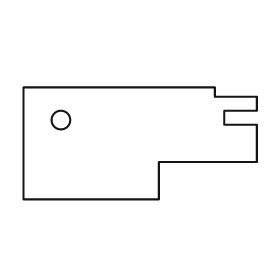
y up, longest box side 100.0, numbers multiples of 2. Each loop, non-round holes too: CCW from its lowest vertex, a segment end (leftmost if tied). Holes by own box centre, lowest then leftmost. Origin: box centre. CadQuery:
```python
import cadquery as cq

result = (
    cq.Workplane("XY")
    .moveTo(-50.0, -24.0)
    .lineTo(8.0, -24.0)
    .lineTo(8.0, -8.0)
    .lineTo(50.0, -8.0)
    .lineTo(50.0, 8.0)
    .lineTo(36.0, 8.0)
    .lineTo(36.0, 14.0)
    .lineTo(50.0, 14.0)
    .lineTo(50.0, 20.0)
    .lineTo(32.0, 20.0)
    .lineTo(32.0, 24.0)
    .lineTo(-50.0, 24.0)
    .close()
    .moveTo(-34.0, 10.0)
    .circle(4.0)
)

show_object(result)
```